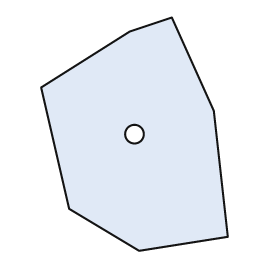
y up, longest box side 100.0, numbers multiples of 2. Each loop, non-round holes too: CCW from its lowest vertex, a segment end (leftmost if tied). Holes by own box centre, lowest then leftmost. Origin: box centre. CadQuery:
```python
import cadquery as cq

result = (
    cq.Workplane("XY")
    .moveTo(2.0, -50.0)
    .lineTo(40.0, -44.0)
    .lineTo(34.0, 10.0)
    .lineTo(16.0, 50.0)
    .lineTo(-2.0, 44.0)
    .lineTo(-40.0, 20.0)
    .lineTo(-28.0, -32.0)
    .close()
    .moveTo(0.0, 0.0)
    .circle(4.0)
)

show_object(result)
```